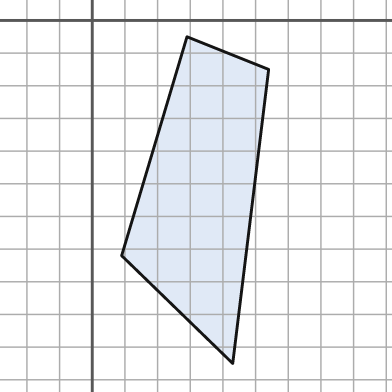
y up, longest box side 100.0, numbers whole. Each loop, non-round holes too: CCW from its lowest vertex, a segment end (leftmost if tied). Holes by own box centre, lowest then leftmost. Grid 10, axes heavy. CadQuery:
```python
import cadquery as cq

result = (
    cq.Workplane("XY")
    .moveTo(43.0, -105.0)
    .lineTo(54.0, -15.0)
    .lineTo(29.0, -5.0)
    .lineTo(9.0, -72.0)
    .close()
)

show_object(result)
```